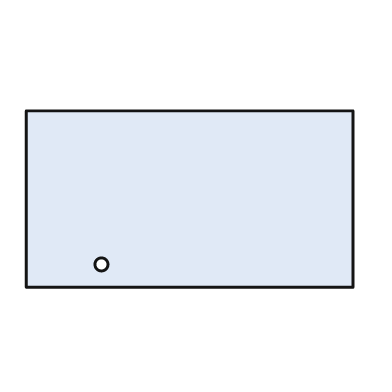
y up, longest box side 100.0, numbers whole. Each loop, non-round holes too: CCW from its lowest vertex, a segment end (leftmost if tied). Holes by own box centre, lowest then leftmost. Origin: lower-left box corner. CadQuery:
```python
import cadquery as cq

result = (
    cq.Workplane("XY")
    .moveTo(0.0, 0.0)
    .lineTo(100.0, 0.0)
    .lineTo(100.0, 54.0)
    .lineTo(0.0, 54.0)
    .close()
    .moveTo(23.0, 7.0)
    .circle(2.0)
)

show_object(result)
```